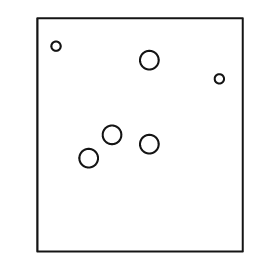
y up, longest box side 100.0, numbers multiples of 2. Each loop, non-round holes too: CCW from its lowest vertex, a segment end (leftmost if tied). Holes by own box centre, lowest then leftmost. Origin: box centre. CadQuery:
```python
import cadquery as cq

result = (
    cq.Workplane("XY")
    .moveTo(-44.0, -50.0)
    .lineTo(44.0, -50.0)
    .lineTo(44.0, 50.0)
    .lineTo(-44.0, 50.0)
    .close()
    .moveTo(-22.0, -10.0)
    .circle(4.0)
    .moveTo(4.0, -4.0)
    .circle(4.0)
    .moveTo(-12.0, 0.0)
    .circle(4.0)
    .moveTo(34.0, 24.0)
    .circle(2.0)
    .moveTo(4.0, 32.0)
    .circle(4.0)
    .moveTo(-36.0, 38.0)
    .circle(2.0)
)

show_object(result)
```